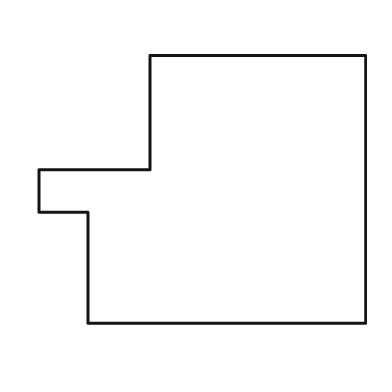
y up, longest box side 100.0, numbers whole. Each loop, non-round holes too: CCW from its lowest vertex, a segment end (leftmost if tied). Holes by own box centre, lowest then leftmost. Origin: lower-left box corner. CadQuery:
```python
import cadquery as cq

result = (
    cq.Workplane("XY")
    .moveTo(15.0, 0.0)
    .lineTo(100.0, 0.0)
    .lineTo(100.0, 82.0)
    .lineTo(34.0, 82.0)
    .lineTo(34.0, 47.0)
    .lineTo(0.0, 47.0)
    .lineTo(0.0, 34.0)
    .lineTo(15.0, 34.0)
    .close()
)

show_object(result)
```